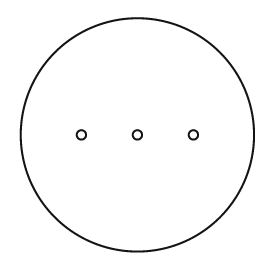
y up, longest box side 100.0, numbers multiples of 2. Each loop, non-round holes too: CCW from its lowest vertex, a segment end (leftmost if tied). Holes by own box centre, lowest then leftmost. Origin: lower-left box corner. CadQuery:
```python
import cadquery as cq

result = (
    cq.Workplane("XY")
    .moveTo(50.0, 50.0)
    .circle(50.0)
    .moveTo(26.0, 50.0)
    .circle(2.0)
    .moveTo(50.0, 50.0)
    .circle(2.0)
    .moveTo(74.0, 50.0)
    .circle(2.0)
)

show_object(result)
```